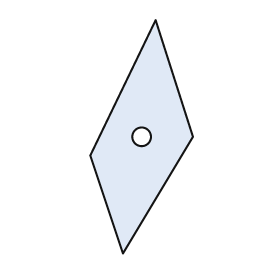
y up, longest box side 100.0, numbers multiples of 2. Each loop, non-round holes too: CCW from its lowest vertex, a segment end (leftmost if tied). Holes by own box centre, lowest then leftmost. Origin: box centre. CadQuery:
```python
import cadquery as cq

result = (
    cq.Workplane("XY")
    .moveTo(-8.0, -50.0)
    .lineTo(22.0, 0.0)
    .lineTo(6.0, 50.0)
    .lineTo(-22.0, -8.0)
    .close()
    .moveTo(0.0, 0.0)
    .circle(4.0)
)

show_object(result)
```